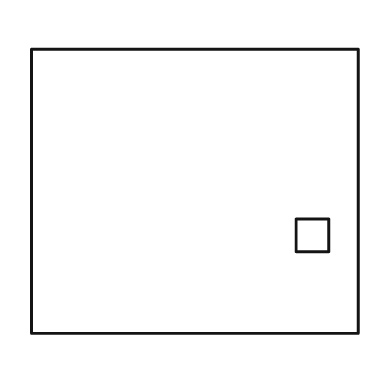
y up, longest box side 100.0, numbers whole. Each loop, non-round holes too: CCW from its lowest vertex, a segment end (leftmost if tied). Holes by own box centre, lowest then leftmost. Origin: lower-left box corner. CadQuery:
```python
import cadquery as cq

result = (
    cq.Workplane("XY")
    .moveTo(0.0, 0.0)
    .lineTo(100.0, 0.0)
    .lineTo(100.0, 87.0)
    .lineTo(0.0, 87.0)
    .close()
    .moveTo(81.0, 25.0)
    .lineTo(91.0, 25.0)
    .lineTo(91.0, 35.0)
    .lineTo(81.0, 35.0)
    .close()
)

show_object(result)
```